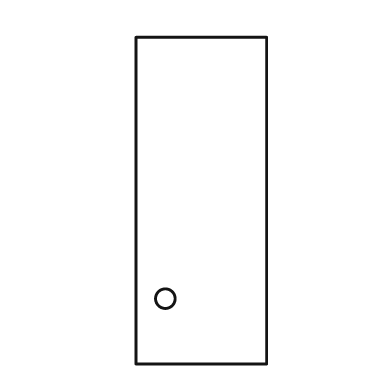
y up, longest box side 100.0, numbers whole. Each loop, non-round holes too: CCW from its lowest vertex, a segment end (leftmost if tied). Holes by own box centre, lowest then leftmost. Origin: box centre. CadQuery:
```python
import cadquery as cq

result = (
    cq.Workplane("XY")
    .moveTo(-20.0, -50.0)
    .lineTo(20.0, -50.0)
    .lineTo(20.0, 50.0)
    .lineTo(-20.0, 50.0)
    .close()
    .moveTo(-11.0, -30.0)
    .circle(3.0)
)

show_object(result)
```